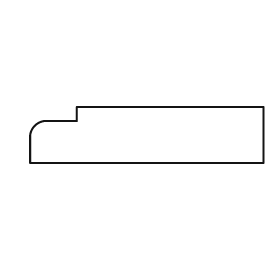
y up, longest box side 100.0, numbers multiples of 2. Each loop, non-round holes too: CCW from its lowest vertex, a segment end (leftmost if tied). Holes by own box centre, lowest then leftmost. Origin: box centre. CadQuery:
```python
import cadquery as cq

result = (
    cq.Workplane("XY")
    .moveTo(-50.0, -12.0)
    .lineTo(50.0, -12.0)
    .lineTo(50.0, 12.0)
    .lineTo(-30.0, 12.0)
    .lineTo(-30.0, 6.0)
    .lineTo(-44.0, 6.0)
    .threePointArc((-48.0, 4.0), (-50.0, 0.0))
    .close()
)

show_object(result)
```